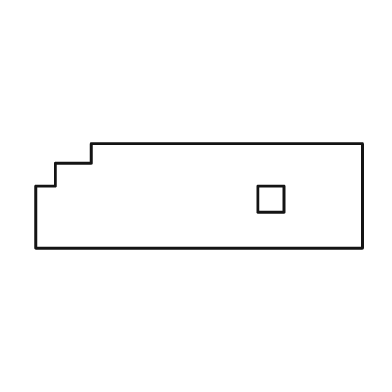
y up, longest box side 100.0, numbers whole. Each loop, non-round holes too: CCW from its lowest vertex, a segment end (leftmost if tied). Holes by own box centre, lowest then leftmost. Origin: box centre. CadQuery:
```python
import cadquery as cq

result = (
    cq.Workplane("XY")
    .moveTo(-50.0, -16.0)
    .lineTo(50.0, -16.0)
    .lineTo(50.0, 16.0)
    .lineTo(-33.0, 16.0)
    .lineTo(-33.0, 10.0)
    .lineTo(-44.0, 10.0)
    .lineTo(-44.0, 3.0)
    .lineTo(-50.0, 3.0)
    .close()
    .moveTo(18.0, -5.0)
    .lineTo(26.0, -5.0)
    .lineTo(26.0, 3.0)
    .lineTo(18.0, 3.0)
    .close()
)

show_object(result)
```